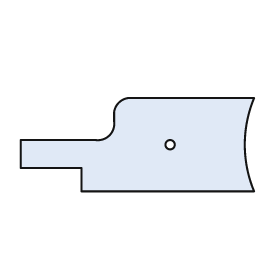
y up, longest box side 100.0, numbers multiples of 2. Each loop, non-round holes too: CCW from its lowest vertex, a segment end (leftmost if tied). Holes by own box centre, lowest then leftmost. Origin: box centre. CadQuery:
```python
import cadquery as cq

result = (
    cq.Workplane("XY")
    .moveTo(-24.0, -20.0)
    .lineTo(50.0, -20.0)
    .threePointArc((46.0, 0.0), (50.0, 20.0))
    .lineTo(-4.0, 20.0)
    .threePointArc((-8.0, 18.0), (-10.0, 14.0))
    .lineTo(-10.0, 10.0)
    .threePointArc((-12.0, 4.0), (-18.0, 2.0))
    .lineTo(-50.0, 2.0)
    .lineTo(-50.0, -10.0)
    .lineTo(-24.0, -10.0)
    .close()
    .moveTo(14.0, 0.0)
    .circle(2.0)
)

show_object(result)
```